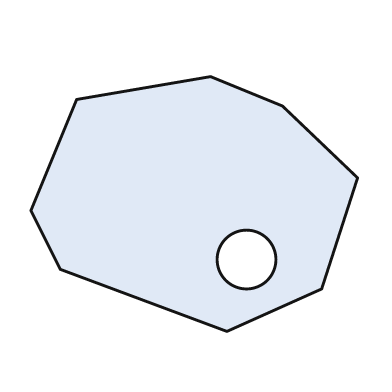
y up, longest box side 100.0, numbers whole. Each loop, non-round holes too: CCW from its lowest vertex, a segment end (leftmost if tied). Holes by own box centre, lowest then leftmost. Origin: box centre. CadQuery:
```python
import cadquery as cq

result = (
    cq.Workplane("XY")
    .moveTo(10.0, -39.0)
    .lineTo(39.0, -26.0)
    .lineTo(50.0, 8.0)
    .lineTo(27.0, 30.0)
    .lineTo(5.0, 39.0)
    .lineTo(-36.0, 32.0)
    .lineTo(-50.0, -2.0)
    .lineTo(-41.0, -20.0)
    .close()
    .moveTo(16.0, -17.0)
    .circle(9.0)
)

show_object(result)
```